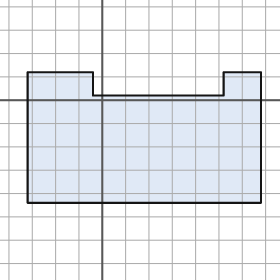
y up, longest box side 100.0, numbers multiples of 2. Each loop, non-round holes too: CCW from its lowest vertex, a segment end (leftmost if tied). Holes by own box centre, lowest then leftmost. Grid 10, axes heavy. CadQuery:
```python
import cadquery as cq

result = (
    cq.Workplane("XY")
    .moveTo(-32.0, -44.0)
    .lineTo(68.0, -44.0)
    .lineTo(68.0, 12.0)
    .lineTo(52.0, 12.0)
    .lineTo(52.0, 2.0)
    .lineTo(-4.0, 2.0)
    .lineTo(-4.0, 12.0)
    .lineTo(-32.0, 12.0)
    .close()
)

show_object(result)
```